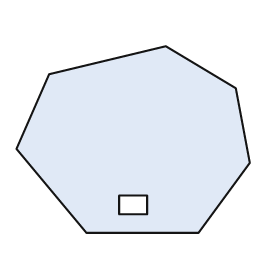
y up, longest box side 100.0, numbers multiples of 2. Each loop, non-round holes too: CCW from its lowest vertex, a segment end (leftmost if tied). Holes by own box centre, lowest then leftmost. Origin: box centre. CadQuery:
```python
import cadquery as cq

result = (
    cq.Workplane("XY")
    .moveTo(-20.0, -40.0)
    .lineTo(28.0, -40.0)
    .lineTo(50.0, -10.0)
    .lineTo(44.0, 22.0)
    .lineTo(14.0, 40.0)
    .lineTo(-36.0, 28.0)
    .lineTo(-50.0, -4.0)
    .close()
    .moveTo(-6.0, -32.0)
    .lineTo(6.0, -32.0)
    .lineTo(6.0, -24.0)
    .lineTo(-6.0, -24.0)
    .close()
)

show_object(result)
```